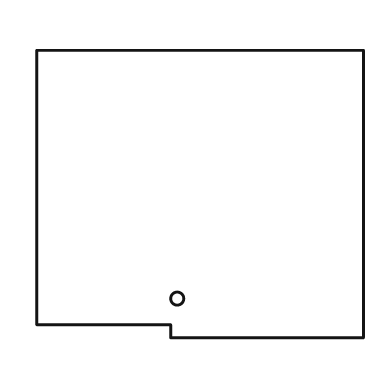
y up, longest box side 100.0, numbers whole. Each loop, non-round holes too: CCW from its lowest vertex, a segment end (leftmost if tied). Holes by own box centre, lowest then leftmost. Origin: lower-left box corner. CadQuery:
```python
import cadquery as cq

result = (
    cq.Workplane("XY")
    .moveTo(41.0, 0.0)
    .lineTo(100.0, 0.0)
    .lineTo(100.0, 88.0)
    .lineTo(0.0, 88.0)
    .lineTo(0.0, 4.0)
    .lineTo(41.0, 4.0)
    .close()
    .moveTo(43.0, 12.0)
    .circle(2.0)
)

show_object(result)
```